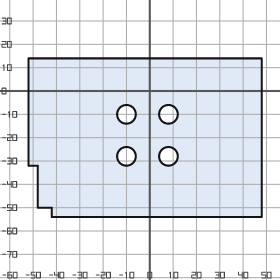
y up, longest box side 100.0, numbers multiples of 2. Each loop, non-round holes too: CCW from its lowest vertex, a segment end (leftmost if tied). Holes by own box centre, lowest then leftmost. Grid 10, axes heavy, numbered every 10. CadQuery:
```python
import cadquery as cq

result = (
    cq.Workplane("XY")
    .moveTo(-42.0, -54.0)
    .lineTo(48.0, -54.0)
    .lineTo(48.0, 14.0)
    .lineTo(-52.0, 14.0)
    .lineTo(-52.0, -32.0)
    .lineTo(-48.0, -32.0)
    .lineTo(-48.0, -50.0)
    .lineTo(-42.0, -50.0)
    .close()
    .moveTo(-10.0, -28.0)
    .circle(4.0)
    .moveTo(8.0, -28.0)
    .circle(4.0)
    .moveTo(-10.0, -10.0)
    .circle(4.0)
    .moveTo(8.0, -10.0)
    .circle(4.0)
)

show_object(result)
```